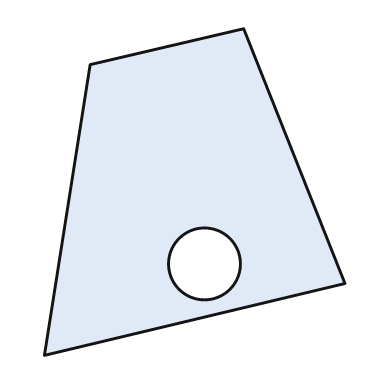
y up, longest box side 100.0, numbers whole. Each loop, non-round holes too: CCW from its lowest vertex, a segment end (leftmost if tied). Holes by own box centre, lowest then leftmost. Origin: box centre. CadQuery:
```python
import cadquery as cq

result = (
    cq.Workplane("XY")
    .moveTo(-46.0, -50.0)
    .lineTo(46.0, -28.0)
    .lineTo(15.0, 50.0)
    .lineTo(-32.0, 39.0)
    .close()
    .moveTo(3.0, -22.0)
    .circle(11.0)
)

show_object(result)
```